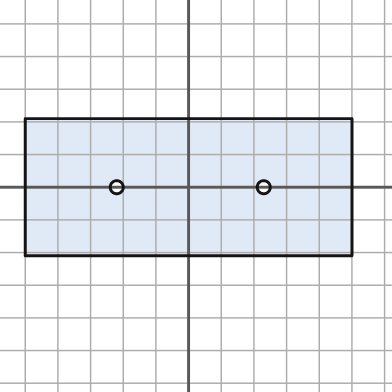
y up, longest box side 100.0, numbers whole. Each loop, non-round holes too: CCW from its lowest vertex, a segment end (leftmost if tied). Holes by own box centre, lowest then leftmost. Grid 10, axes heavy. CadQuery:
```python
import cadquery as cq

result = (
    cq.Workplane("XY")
    .moveTo(-50.0, -21.0)
    .lineTo(50.0, -21.0)
    .lineTo(50.0, 21.0)
    .lineTo(-50.0, 21.0)
    .close()
    .moveTo(-22.0, 0.0)
    .circle(2.0)
    .moveTo(23.0, 0.0)
    .circle(2.0)
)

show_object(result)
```